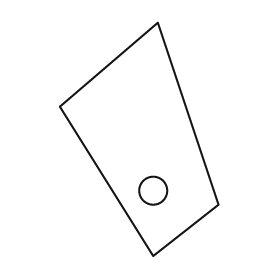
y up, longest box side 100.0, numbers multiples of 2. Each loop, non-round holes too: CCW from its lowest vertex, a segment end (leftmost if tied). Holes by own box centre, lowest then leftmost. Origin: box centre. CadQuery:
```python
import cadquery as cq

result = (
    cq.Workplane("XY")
    .moveTo(6.0, -50.0)
    .lineTo(34.0, -28.0)
    .lineTo(8.0, 50.0)
    .lineTo(-34.0, 14.0)
    .close()
    .moveTo(6.0, -22.0)
    .circle(6.0)
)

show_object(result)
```